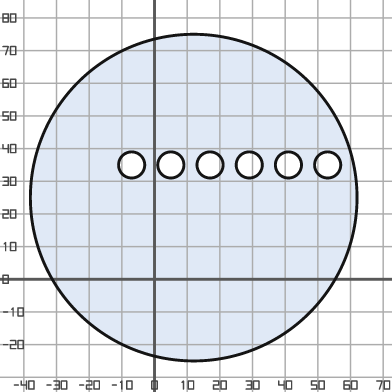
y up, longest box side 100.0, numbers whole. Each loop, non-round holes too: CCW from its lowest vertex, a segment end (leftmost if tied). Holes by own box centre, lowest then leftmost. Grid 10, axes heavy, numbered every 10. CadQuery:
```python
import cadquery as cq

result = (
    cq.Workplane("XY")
    .moveTo(12.0, 25.0)
    .circle(50.0)
    .moveTo(-7.0, 35.0)
    .circle(4.0)
    .moveTo(5.0, 35.0)
    .circle(4.0)
    .moveTo(17.0, 35.0)
    .circle(4.0)
    .moveTo(29.0, 35.0)
    .circle(4.0)
    .moveTo(41.0, 35.0)
    .circle(4.0)
    .moveTo(53.0, 35.0)
    .circle(4.0)
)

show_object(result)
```